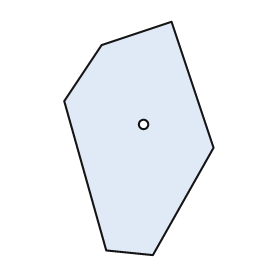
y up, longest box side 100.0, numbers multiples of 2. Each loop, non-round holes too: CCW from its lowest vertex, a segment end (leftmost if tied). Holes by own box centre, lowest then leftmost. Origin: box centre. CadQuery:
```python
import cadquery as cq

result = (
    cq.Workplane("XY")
    .moveTo(6.0, -50.0)
    .lineTo(32.0, -4.0)
    .lineTo(14.0, 50.0)
    .lineTo(-16.0, 40.0)
    .lineTo(-32.0, 16.0)
    .lineTo(-14.0, -48.0)
    .close()
    .moveTo(2.0, 6.0)
    .circle(2.0)
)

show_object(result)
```